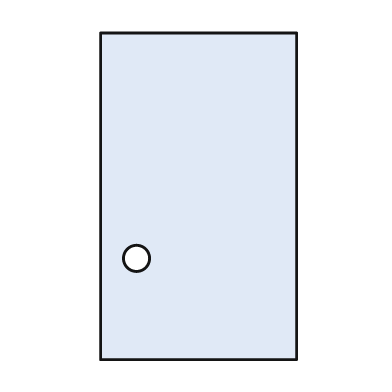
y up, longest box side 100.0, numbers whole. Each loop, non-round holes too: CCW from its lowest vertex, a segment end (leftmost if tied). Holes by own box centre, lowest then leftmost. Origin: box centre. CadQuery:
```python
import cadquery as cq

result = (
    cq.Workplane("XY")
    .moveTo(-30.0, -50.0)
    .lineTo(30.0, -50.0)
    .lineTo(30.0, 50.0)
    .lineTo(-30.0, 50.0)
    .close()
    .moveTo(-19.0, -19.0)
    .circle(4.0)
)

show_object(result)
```